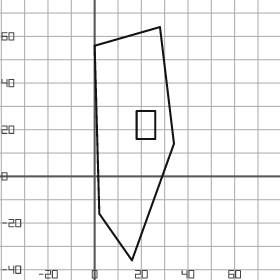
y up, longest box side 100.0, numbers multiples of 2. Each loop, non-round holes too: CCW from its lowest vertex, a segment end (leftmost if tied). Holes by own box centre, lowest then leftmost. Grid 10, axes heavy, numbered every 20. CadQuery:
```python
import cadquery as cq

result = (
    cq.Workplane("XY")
    .moveTo(16.0, -36.0)
    .lineTo(34.0, 14.0)
    .lineTo(28.0, 64.0)
    .lineTo(0.0, 56.0)
    .lineTo(2.0, -16.0)
    .close()
    .moveTo(18.0, 16.0)
    .lineTo(26.0, 16.0)
    .lineTo(26.0, 28.0)
    .lineTo(18.0, 28.0)
    .close()
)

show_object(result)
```